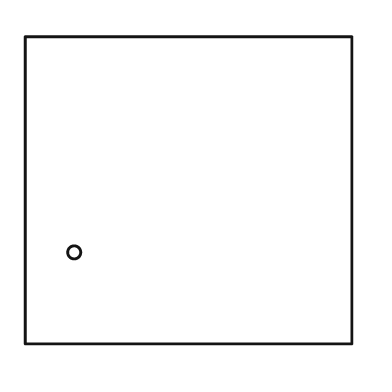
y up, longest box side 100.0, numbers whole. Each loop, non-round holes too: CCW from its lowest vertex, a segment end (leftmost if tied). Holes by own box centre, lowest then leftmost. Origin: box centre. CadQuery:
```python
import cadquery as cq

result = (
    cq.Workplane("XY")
    .moveTo(-50.0, -47.0)
    .lineTo(50.0, -47.0)
    .lineTo(50.0, 47.0)
    .lineTo(-50.0, 47.0)
    .close()
    .moveTo(-35.0, -19.0)
    .circle(2.0)
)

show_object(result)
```